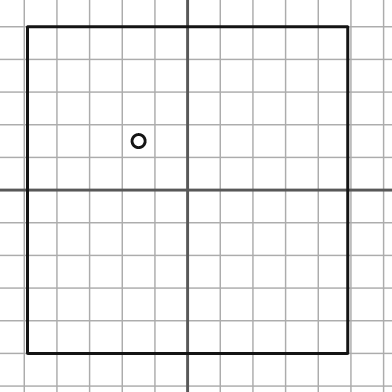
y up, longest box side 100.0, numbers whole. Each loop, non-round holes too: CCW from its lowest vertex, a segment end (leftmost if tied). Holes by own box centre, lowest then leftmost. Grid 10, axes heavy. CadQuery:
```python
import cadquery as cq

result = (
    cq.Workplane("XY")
    .moveTo(-49.0, -50.0)
    .lineTo(49.0, -50.0)
    .lineTo(49.0, 50.0)
    .lineTo(-49.0, 50.0)
    .close()
    .moveTo(-15.0, 15.0)
    .circle(2.0)
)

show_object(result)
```